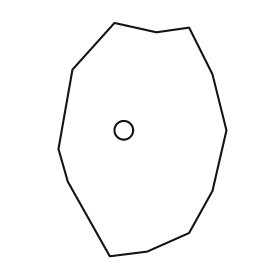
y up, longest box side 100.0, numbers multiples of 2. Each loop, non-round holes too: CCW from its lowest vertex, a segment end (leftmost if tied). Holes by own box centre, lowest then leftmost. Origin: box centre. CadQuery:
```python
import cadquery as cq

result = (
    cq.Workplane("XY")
    .moveTo(-14.0, -50.0)
    .lineTo(2.0, -48.0)
    .lineTo(20.0, -40.0)
    .lineTo(30.0, -22.0)
    .lineTo(36.0, 4.0)
    .lineTo(30.0, 28.0)
    .lineTo(20.0, 48.0)
    .lineTo(6.0, 46.0)
    .lineTo(-12.0, 50.0)
    .lineTo(-30.0, 30.0)
    .lineTo(-36.0, -4.0)
    .lineTo(-32.0, -18.0)
    .close()
    .moveTo(-8.0, 4.0)
    .circle(4.0)
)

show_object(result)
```